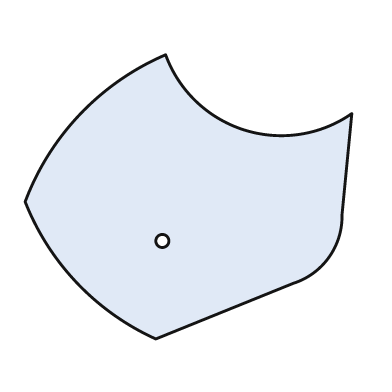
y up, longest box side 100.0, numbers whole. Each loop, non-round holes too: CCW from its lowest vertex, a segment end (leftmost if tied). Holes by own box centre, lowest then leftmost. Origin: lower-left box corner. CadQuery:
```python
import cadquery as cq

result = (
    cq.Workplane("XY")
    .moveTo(40.0, 0.0)
    .lineTo(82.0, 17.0)
    .threePointArc((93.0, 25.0), (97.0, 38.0))
    .lineTo(100.0, 69.0)
    .threePointArc((67.0, 64.0), (43.0, 87.0))
    .threePointArc((17.0, 69.0), (0.0, 42.0))
    .threePointArc((16.0, 17.0), (40.0, 0.0))
    .close()
    .moveTo(42.0, 30.0)
    .circle(2.0)
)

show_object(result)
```